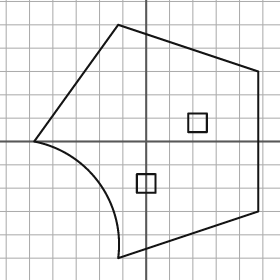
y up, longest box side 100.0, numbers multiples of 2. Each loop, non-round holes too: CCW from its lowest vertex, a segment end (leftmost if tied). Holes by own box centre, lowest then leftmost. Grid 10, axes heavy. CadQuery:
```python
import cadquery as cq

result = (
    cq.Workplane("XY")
    .moveTo(-12.0, -50.0)
    .lineTo(48.0, -30.0)
    .lineTo(48.0, 30.0)
    .lineTo(-12.0, 50.0)
    .lineTo(-48.0, 0.0)
    .threePointArc((-20.0, -18.0), (-12.0, -50.0))
    .close()
    .moveTo(-4.0, -22.0)
    .lineTo(4.0, -22.0)
    .lineTo(4.0, -14.0)
    .lineTo(-4.0, -14.0)
    .close()
    .moveTo(18.0, 4.0)
    .lineTo(26.0, 4.0)
    .lineTo(26.0, 12.0)
    .lineTo(18.0, 12.0)
    .close()
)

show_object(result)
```